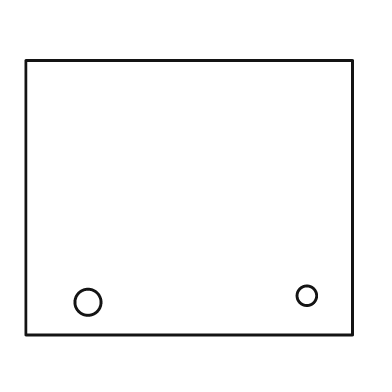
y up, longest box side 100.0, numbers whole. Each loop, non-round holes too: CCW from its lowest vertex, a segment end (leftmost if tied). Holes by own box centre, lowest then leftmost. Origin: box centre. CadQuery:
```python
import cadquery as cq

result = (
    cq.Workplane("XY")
    .moveTo(-50.0, -42.0)
    .lineTo(50.0, -42.0)
    .lineTo(50.0, 42.0)
    .lineTo(-50.0, 42.0)
    .close()
    .moveTo(-31.0, -32.0)
    .circle(4.0)
    .moveTo(36.0, -30.0)
    .circle(3.0)
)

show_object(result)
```